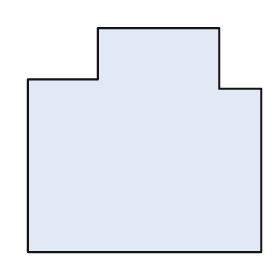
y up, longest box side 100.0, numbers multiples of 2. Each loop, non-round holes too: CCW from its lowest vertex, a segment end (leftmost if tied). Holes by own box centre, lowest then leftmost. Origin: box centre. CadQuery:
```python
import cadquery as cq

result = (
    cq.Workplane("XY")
    .moveTo(-50.0, -48.0)
    .lineTo(50.0, -48.0)
    .lineTo(50.0, 22.0)
    .lineTo(32.0, 22.0)
    .lineTo(32.0, 48.0)
    .lineTo(-20.0, 48.0)
    .lineTo(-20.0, 26.0)
    .lineTo(-50.0, 26.0)
    .close()
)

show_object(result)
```